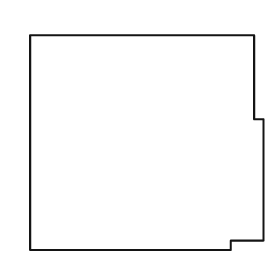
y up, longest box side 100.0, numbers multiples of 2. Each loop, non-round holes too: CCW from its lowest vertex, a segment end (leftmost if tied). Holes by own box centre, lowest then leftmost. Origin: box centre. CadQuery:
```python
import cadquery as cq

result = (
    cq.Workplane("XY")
    .moveTo(-50.0, -46.0)
    .lineTo(36.0, -46.0)
    .lineTo(36.0, -42.0)
    .lineTo(50.0, -42.0)
    .lineTo(50.0, 10.0)
    .lineTo(46.0, 10.0)
    .lineTo(46.0, 46.0)
    .lineTo(-50.0, 46.0)
    .close()
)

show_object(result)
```